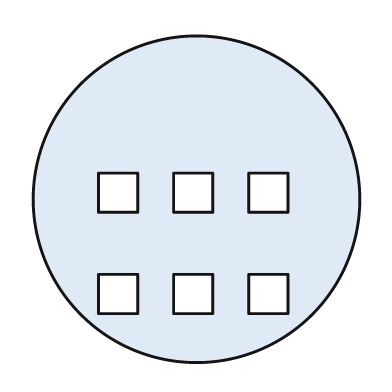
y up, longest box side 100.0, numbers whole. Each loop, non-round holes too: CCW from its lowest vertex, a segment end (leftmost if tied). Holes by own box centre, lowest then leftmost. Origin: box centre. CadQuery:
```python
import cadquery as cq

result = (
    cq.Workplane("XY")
    .moveTo(0.0, 0.0)
    .circle(50.0)
    .moveTo(-30.0, -35.0)
    .lineTo(-18.0, -35.0)
    .lineTo(-18.0, -23.0)
    .lineTo(-30.0, -23.0)
    .close()
    .moveTo(-7.0, -35.0)
    .lineTo(5.0, -35.0)
    .lineTo(5.0, -23.0)
    .lineTo(-7.0, -23.0)
    .close()
    .moveTo(16.0, -35.0)
    .lineTo(28.0, -35.0)
    .lineTo(28.0, -23.0)
    .lineTo(16.0, -23.0)
    .close()
    .moveTo(-30.0, -4.0)
    .lineTo(-18.0, -4.0)
    .lineTo(-18.0, 8.0)
    .lineTo(-30.0, 8.0)
    .close()
    .moveTo(-7.0, -4.0)
    .lineTo(5.0, -4.0)
    .lineTo(5.0, 8.0)
    .lineTo(-7.0, 8.0)
    .close()
    .moveTo(16.0, -4.0)
    .lineTo(28.0, -4.0)
    .lineTo(28.0, 8.0)
    .lineTo(16.0, 8.0)
    .close()
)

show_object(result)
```